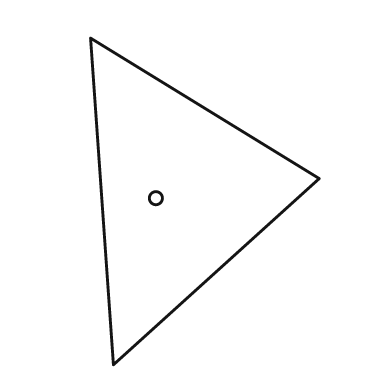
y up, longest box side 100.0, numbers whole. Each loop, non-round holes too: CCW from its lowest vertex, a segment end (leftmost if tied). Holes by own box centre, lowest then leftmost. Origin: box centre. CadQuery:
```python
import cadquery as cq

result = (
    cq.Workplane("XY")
    .moveTo(-28.0, -50.0)
    .lineTo(35.0, 7.0)
    .lineTo(-35.0, 50.0)
    .close()
    .moveTo(-15.0, 1.0)
    .circle(2.0)
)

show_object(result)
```